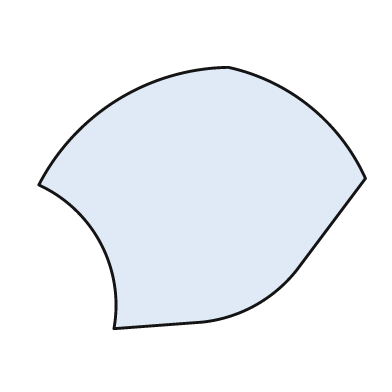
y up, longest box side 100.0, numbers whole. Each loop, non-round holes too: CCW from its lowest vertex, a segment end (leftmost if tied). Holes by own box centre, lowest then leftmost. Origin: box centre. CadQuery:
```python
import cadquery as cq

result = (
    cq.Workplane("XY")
    .moveTo(-27.0, -40.0)
    .lineTo(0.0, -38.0)
    .threePointArc((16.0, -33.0), (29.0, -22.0))
    .lineTo(50.0, 6.0)
    .threePointArc((33.0, 28.0), (8.0, 40.0))
    .threePointArc((-26.0, 30.0), (-50.0, 4.0))
    .threePointArc((-31.0, -14.0), (-27.0, -40.0))
    .close()
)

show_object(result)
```